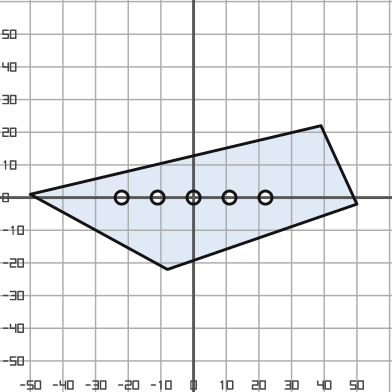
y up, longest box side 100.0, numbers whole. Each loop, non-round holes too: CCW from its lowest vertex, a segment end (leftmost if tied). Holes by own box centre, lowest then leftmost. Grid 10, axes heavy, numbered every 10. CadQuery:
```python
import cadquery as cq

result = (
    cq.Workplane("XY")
    .moveTo(-8.0, -22.0)
    .lineTo(50.0, -2.0)
    .lineTo(39.0, 22.0)
    .lineTo(-50.0, 1.0)
    .close()
    .moveTo(-22.0, 0.0)
    .circle(2.0)
    .moveTo(-11.0, 0.0)
    .circle(2.0)
    .moveTo(0.0, 0.0)
    .circle(2.0)
    .moveTo(11.0, 0.0)
    .circle(2.0)
    .moveTo(22.0, 0.0)
    .circle(2.0)
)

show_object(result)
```